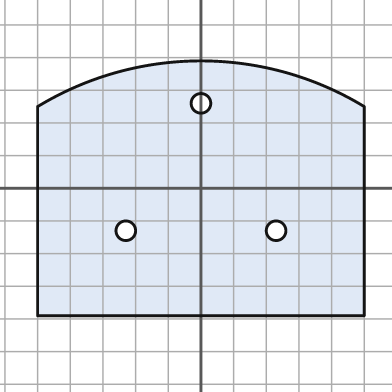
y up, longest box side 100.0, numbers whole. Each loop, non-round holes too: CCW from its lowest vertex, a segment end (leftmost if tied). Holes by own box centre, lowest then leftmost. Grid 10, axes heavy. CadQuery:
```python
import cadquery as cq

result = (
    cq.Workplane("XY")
    .moveTo(-50.0, -39.0)
    .lineTo(50.0, -39.0)
    .lineTo(50.0, 25.0)
    .threePointArc((0.0, 39.0), (-50.0, 25.0))
    .close()
    .moveTo(-23.0, -13.0)
    .circle(3.0)
    .moveTo(23.0, -13.0)
    .circle(3.0)
    .moveTo(0.0, 26.0)
    .circle(3.0)
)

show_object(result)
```